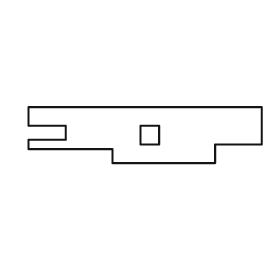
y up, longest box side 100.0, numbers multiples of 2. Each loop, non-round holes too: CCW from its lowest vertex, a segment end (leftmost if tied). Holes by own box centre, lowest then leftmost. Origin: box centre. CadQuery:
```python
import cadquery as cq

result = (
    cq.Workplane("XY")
    .moveTo(-14.0, -12.0)
    .lineTo(30.0, -12.0)
    .lineTo(30.0, -4.0)
    .lineTo(50.0, -4.0)
    .lineTo(50.0, 12.0)
    .lineTo(-50.0, 12.0)
    .lineTo(-50.0, 4.0)
    .lineTo(-34.0, 4.0)
    .lineTo(-34.0, -2.0)
    .lineTo(-50.0, -2.0)
    .lineTo(-50.0, -6.0)
    .lineTo(-14.0, -6.0)
    .close()
    .moveTo(-2.0, -4.0)
    .lineTo(6.0, -4.0)
    .lineTo(6.0, 4.0)
    .lineTo(-2.0, 4.0)
    .close()
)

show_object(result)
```